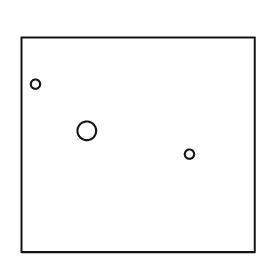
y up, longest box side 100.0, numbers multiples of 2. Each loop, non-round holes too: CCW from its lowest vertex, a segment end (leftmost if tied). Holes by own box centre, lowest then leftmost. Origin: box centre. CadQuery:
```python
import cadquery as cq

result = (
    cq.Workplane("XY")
    .moveTo(-50.0, -46.0)
    .lineTo(50.0, -46.0)
    .lineTo(50.0, 46.0)
    .lineTo(-50.0, 46.0)
    .close()
    .moveTo(22.0, -4.0)
    .circle(2.0)
    .moveTo(-22.0, 6.0)
    .circle(4.0)
    .moveTo(-44.0, 26.0)
    .circle(2.0)
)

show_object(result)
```